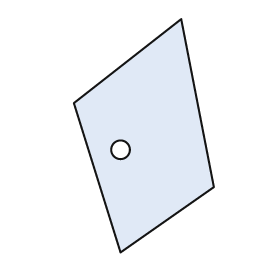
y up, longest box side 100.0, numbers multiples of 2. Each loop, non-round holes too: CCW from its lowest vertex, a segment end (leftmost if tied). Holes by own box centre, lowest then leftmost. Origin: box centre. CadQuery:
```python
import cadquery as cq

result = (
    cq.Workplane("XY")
    .moveTo(-10.0, -50.0)
    .lineTo(30.0, -22.0)
    .lineTo(16.0, 50.0)
    .lineTo(-30.0, 14.0)
    .close()
    .moveTo(-10.0, -6.0)
    .circle(4.0)
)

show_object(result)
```